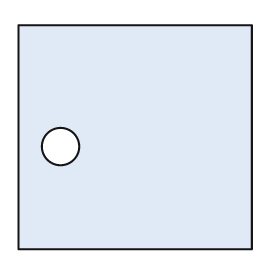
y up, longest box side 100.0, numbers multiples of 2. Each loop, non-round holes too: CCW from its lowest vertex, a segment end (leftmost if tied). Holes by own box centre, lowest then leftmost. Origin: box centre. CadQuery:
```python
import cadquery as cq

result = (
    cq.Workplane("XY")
    .moveTo(-50.0, -48.0)
    .lineTo(50.0, -48.0)
    .lineTo(50.0, 48.0)
    .lineTo(-50.0, 48.0)
    .close()
    .moveTo(-32.0, -4.0)
    .circle(8.0)
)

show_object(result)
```